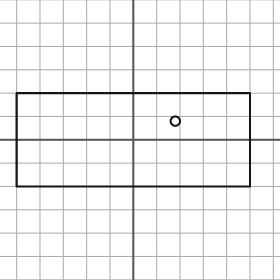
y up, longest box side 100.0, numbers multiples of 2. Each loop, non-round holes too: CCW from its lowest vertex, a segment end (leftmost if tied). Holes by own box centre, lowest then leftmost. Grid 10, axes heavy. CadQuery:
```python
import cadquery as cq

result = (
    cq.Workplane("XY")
    .moveTo(-50.0, -20.0)
    .lineTo(50.0, -20.0)
    .lineTo(50.0, 20.0)
    .lineTo(-50.0, 20.0)
    .close()
    .moveTo(18.0, 8.0)
    .circle(2.0)
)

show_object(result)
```